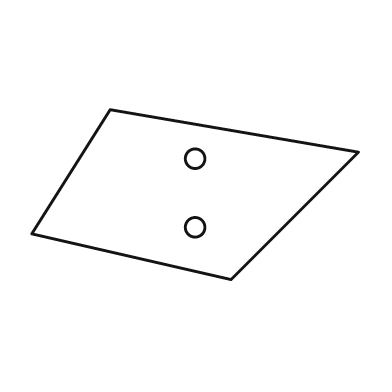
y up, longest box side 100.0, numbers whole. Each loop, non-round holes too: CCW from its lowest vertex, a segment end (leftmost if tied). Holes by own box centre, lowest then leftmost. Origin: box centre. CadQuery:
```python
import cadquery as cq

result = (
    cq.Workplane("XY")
    .moveTo(11.0, -26.0)
    .lineTo(50.0, 13.0)
    .lineTo(-26.0, 26.0)
    .lineTo(-50.0, -12.0)
    .close()
    .moveTo(0.0, -10.0)
    .circle(3.0)
    .moveTo(0.0, 11.0)
    .circle(3.0)
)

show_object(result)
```